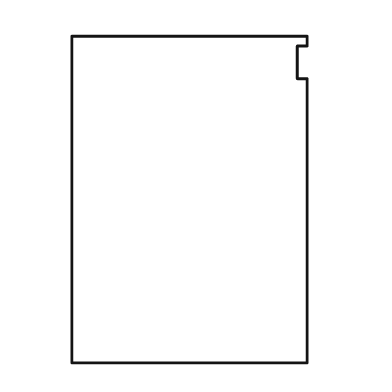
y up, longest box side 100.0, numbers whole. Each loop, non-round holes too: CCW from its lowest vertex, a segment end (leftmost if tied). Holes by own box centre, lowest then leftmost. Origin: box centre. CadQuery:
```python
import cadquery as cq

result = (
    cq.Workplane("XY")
    .moveTo(-36.0, -50.0)
    .lineTo(36.0, -50.0)
    .lineTo(36.0, 37.0)
    .lineTo(33.0, 37.0)
    .lineTo(33.0, 47.0)
    .lineTo(36.0, 47.0)
    .lineTo(36.0, 50.0)
    .lineTo(-36.0, 50.0)
    .close()
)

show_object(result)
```